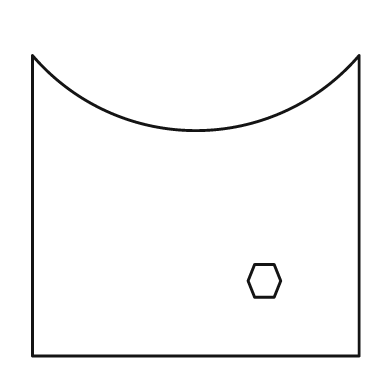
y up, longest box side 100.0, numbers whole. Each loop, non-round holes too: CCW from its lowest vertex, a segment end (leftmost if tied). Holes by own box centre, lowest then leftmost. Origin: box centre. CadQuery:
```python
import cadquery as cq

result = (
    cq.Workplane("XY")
    .moveTo(-50.0, -46.0)
    .lineTo(50.0, -46.0)
    .lineTo(50.0, 46.0)
    .threePointArc((0.0, 23.0), (-50.0, 46.0))
    .close()
    .moveTo(18.0, -28.0)
    .lineTo(24.0, -28.0)
    .lineTo(26.0, -23.0)
    .lineTo(24.0, -18.0)
    .lineTo(18.0, -18.0)
    .lineTo(16.0, -23.0)
    .close()
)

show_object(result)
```